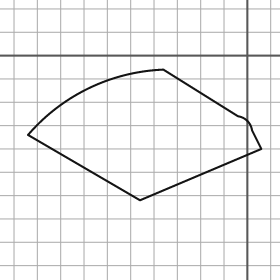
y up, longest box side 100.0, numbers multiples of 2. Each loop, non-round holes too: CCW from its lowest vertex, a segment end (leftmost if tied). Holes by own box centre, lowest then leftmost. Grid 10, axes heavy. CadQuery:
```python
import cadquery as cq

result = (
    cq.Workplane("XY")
    .moveTo(-46.0, -62.0)
    .lineTo(6.0, -40.0)
    .lineTo(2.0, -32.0)
    .threePointArc((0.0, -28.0), (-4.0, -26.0))
    .lineTo(-36.0, -6.0)
    .threePointArc((-68.0, -14.0), (-94.0, -34.0))
    .close()
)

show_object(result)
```